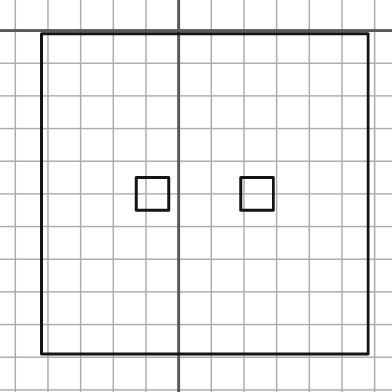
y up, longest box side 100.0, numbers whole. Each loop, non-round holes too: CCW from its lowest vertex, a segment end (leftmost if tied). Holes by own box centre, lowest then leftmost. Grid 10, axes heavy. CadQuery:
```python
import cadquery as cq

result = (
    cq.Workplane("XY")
    .moveTo(-42.0, -99.0)
    .lineTo(58.0, -99.0)
    .lineTo(58.0, -1.0)
    .lineTo(-42.0, -1.0)
    .close()
    .moveTo(-13.0, -55.0)
    .lineTo(-3.0, -55.0)
    .lineTo(-3.0, -45.0)
    .lineTo(-13.0, -45.0)
    .close()
    .moveTo(19.0, -55.0)
    .lineTo(29.0, -55.0)
    .lineTo(29.0, -45.0)
    .lineTo(19.0, -45.0)
    .close()
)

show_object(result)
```